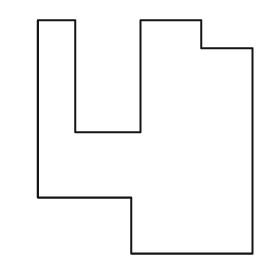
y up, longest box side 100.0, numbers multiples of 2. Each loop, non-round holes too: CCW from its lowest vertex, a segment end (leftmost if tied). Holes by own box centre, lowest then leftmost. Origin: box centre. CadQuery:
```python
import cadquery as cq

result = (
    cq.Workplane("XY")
    .moveTo(-6.0, -50.0)
    .lineTo(46.0, -50.0)
    .lineTo(46.0, 38.0)
    .lineTo(24.0, 38.0)
    .lineTo(24.0, 50.0)
    .lineTo(-2.0, 50.0)
    .lineTo(-2.0, 2.0)
    .lineTo(-30.0, 2.0)
    .lineTo(-30.0, 50.0)
    .lineTo(-46.0, 50.0)
    .lineTo(-46.0, -26.0)
    .lineTo(-6.0, -26.0)
    .close()
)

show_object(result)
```